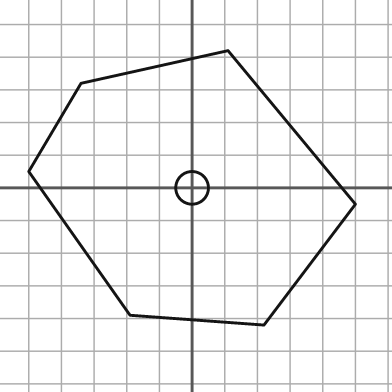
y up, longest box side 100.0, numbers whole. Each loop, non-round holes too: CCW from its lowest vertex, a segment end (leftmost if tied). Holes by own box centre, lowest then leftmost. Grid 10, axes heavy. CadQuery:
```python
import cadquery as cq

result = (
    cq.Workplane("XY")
    .moveTo(22.0, -42.0)
    .lineTo(50.0, -5.0)
    .lineTo(11.0, 42.0)
    .lineTo(-34.0, 32.0)
    .lineTo(-50.0, 5.0)
    .lineTo(-19.0, -39.0)
    .close()
    .moveTo(0.0, 0.0)
    .circle(5.0)
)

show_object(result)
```